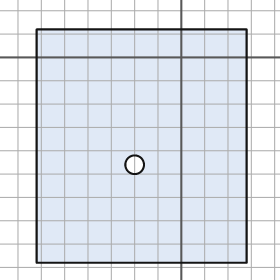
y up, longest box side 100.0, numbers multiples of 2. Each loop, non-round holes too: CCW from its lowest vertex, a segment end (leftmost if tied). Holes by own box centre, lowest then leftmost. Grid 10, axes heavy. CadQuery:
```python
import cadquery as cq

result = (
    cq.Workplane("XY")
    .moveTo(-62.0, -88.0)
    .lineTo(28.0, -88.0)
    .lineTo(28.0, 12.0)
    .lineTo(-62.0, 12.0)
    .close()
    .moveTo(-20.0, -46.0)
    .circle(4.0)
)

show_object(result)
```